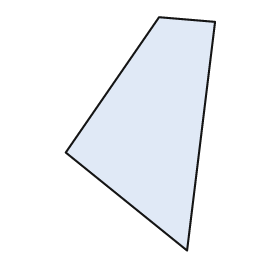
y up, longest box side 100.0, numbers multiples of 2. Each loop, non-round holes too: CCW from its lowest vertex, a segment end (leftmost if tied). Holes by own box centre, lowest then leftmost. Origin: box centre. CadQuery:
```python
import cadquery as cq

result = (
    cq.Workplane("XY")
    .moveTo(20.0, -50.0)
    .lineTo(32.0, 48.0)
    .lineTo(8.0, 50.0)
    .lineTo(-32.0, -8.0)
    .close()
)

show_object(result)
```